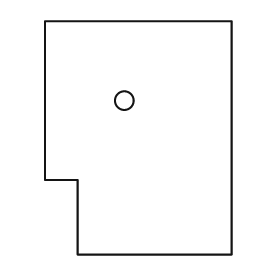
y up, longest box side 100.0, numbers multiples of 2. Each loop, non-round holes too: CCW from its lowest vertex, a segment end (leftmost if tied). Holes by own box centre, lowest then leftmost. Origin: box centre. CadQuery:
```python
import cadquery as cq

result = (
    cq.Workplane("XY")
    .moveTo(-26.0, -50.0)
    .lineTo(40.0, -50.0)
    .lineTo(40.0, 50.0)
    .lineTo(-40.0, 50.0)
    .lineTo(-40.0, -18.0)
    .lineTo(-26.0, -18.0)
    .close()
    .moveTo(-6.0, 16.0)
    .circle(4.0)
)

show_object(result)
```